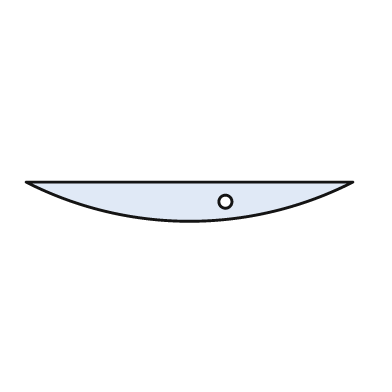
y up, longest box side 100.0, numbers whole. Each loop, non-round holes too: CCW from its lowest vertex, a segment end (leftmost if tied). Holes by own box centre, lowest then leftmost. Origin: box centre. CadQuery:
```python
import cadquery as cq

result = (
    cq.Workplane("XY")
    .moveTo(-50.0, 6.0)
    .threePointArc((0.0, -6.0), (50.0, 6.0))
    .close()
    .moveTo(11.0, 0.0)
    .circle(2.0)
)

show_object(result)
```